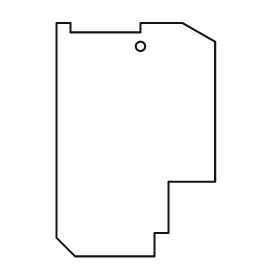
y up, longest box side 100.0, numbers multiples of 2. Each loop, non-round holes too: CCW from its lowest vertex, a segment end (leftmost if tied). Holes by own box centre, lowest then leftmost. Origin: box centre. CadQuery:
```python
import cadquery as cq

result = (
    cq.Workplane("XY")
    .moveTo(-26.0, -50.0)
    .lineTo(8.0, -50.0)
    .lineTo(8.0, -40.0)
    .lineTo(14.0, -40.0)
    .lineTo(14.0, -18.0)
    .lineTo(34.0, -18.0)
    .lineTo(34.0, 42.0)
    .lineTo(20.0, 50.0)
    .lineTo(2.0, 50.0)
    .lineTo(2.0, 46.0)
    .lineTo(-28.0, 46.0)
    .lineTo(-28.0, 50.0)
    .lineTo(-34.0, 50.0)
    .lineTo(-34.0, -42.0)
    .close()
    .moveTo(2.0, 40.0)
    .circle(2.0)
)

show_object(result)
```